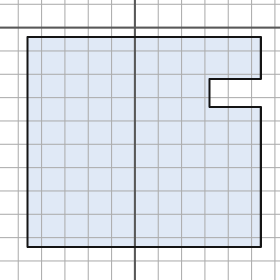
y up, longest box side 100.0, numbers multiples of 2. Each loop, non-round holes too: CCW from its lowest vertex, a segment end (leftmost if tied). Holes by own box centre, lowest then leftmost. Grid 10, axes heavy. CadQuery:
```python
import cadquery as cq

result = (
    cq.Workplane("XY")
    .moveTo(-46.0, -94.0)
    .lineTo(54.0, -94.0)
    .lineTo(54.0, -34.0)
    .lineTo(32.0, -34.0)
    .lineTo(32.0, -22.0)
    .lineTo(54.0, -22.0)
    .lineTo(54.0, -4.0)
    .lineTo(-46.0, -4.0)
    .close()
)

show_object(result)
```